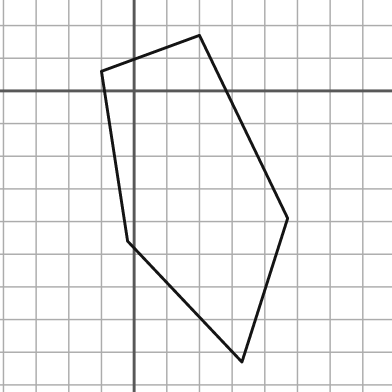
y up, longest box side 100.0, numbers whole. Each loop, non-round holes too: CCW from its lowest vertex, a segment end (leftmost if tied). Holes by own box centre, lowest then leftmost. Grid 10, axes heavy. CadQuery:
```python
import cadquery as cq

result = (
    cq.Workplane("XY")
    .moveTo(33.0, -83.0)
    .lineTo(47.0, -39.0)
    .lineTo(20.0, 17.0)
    .lineTo(-10.0, 6.0)
    .lineTo(-2.0, -46.0)
    .close()
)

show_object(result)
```